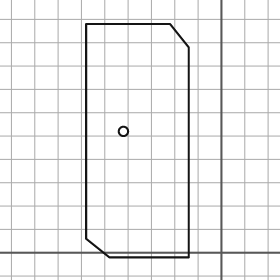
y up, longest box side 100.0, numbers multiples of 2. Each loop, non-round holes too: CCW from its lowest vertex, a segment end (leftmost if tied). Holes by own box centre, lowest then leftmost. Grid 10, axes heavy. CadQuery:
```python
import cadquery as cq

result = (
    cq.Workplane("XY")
    .moveTo(-48.0, -2.0)
    .lineTo(-14.0, -2.0)
    .lineTo(-14.0, 88.0)
    .lineTo(-22.0, 98.0)
    .lineTo(-58.0, 98.0)
    .lineTo(-58.0, 6.0)
    .close()
    .moveTo(-42.0, 52.0)
    .circle(2.0)
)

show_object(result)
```